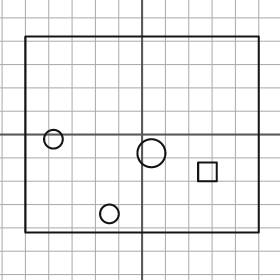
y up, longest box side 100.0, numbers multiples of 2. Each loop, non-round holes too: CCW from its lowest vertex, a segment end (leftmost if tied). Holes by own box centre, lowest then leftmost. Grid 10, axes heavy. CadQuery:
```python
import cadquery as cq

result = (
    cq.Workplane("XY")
    .moveTo(-50.0, -42.0)
    .lineTo(50.0, -42.0)
    .lineTo(50.0, 42.0)
    .lineTo(-50.0, 42.0)
    .close()
    .moveTo(-14.0, -34.0)
    .circle(4.0)
    .moveTo(24.0, -20.0)
    .lineTo(32.0, -20.0)
    .lineTo(32.0, -12.0)
    .lineTo(24.0, -12.0)
    .close()
    .moveTo(4.0, -8.0)
    .circle(6.0)
    .moveTo(-38.0, -2.0)
    .circle(4.0)
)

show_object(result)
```